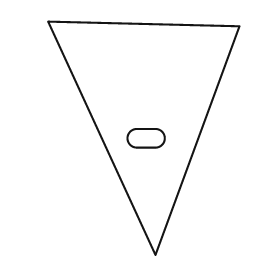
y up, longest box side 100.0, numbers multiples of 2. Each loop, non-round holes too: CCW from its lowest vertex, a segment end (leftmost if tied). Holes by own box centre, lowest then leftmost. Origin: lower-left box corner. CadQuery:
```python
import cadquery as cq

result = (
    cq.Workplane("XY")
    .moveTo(46.0, 0.0)
    .lineTo(82.0, 98.0)
    .lineTo(0.0, 100.0)
    .close()
    .moveTo(38.0, 46.0)
    .lineTo(46.0, 46.0)
    .threePointArc((50.0, 50.0), (46.0, 54.0))
    .lineTo(38.0, 54.0)
    .threePointArc((34.0, 50.0), (38.0, 46.0))
    .close()
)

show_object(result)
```